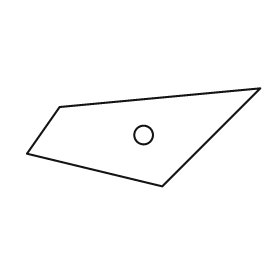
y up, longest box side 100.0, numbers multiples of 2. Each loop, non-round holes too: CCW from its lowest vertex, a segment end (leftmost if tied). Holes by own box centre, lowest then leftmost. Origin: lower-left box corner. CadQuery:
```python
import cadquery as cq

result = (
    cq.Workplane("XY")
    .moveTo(58.0, 0.0)
    .lineTo(100.0, 42.0)
    .lineTo(14.0, 34.0)
    .lineTo(0.0, 14.0)
    .close()
    .moveTo(50.0, 22.0)
    .circle(4.0)
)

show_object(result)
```